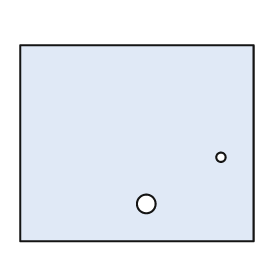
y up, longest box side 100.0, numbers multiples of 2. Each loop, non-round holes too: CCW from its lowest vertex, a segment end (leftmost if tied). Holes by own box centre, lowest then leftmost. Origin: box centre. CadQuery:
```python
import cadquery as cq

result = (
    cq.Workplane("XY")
    .moveTo(-50.0, -42.0)
    .lineTo(50.0, -42.0)
    .lineTo(50.0, 42.0)
    .lineTo(-50.0, 42.0)
    .close()
    .moveTo(4.0, -26.0)
    .circle(4.0)
    .moveTo(36.0, -6.0)
    .circle(2.0)
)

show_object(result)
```